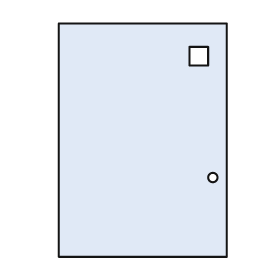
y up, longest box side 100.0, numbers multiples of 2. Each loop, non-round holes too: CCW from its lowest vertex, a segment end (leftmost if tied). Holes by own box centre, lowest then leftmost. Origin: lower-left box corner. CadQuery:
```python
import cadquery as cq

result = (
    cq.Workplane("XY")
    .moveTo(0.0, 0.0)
    .lineTo(72.0, 0.0)
    .lineTo(72.0, 100.0)
    .lineTo(0.0, 100.0)
    .close()
    .moveTo(66.0, 34.0)
    .circle(2.0)
    .moveTo(56.0, 82.0)
    .lineTo(64.0, 82.0)
    .lineTo(64.0, 90.0)
    .lineTo(56.0, 90.0)
    .close()
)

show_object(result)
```